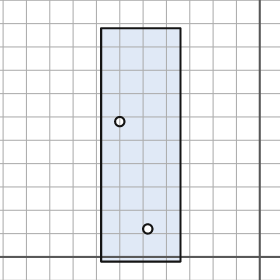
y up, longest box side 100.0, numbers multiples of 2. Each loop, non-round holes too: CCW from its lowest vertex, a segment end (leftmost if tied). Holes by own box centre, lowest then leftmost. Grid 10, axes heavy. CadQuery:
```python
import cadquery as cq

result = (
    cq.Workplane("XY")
    .moveTo(-68.0, -2.0)
    .lineTo(-34.0, -2.0)
    .lineTo(-34.0, 98.0)
    .lineTo(-68.0, 98.0)
    .close()
    .moveTo(-48.0, 12.0)
    .circle(2.0)
    .moveTo(-60.0, 58.0)
    .circle(2.0)
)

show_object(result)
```